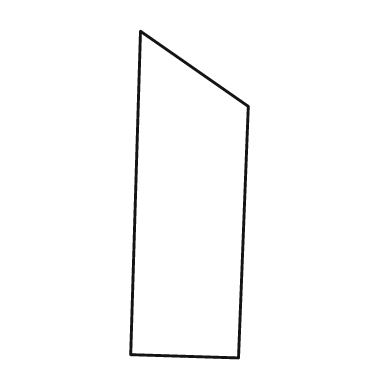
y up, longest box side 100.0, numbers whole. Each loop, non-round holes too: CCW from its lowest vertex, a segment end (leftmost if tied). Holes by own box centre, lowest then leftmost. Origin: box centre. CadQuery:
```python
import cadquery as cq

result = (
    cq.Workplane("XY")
    .moveTo(15.0, -50.0)
    .lineTo(18.0, 27.0)
    .lineTo(-15.0, 50.0)
    .lineTo(-18.0, -49.0)
    .close()
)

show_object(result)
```